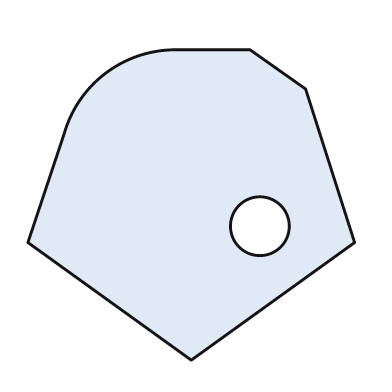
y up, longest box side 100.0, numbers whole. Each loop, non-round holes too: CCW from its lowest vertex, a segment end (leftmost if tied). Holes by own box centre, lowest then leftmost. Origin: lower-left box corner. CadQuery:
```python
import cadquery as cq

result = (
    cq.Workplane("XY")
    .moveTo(50.0, 0.0)
    .lineTo(100.0, 36.0)
    .lineTo(85.0, 83.0)
    .lineTo(68.0, 95.0)
    .lineTo(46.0, 95.0)
    .threePointArc((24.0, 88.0), (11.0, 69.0))
    .lineTo(0.0, 36.0)
    .close()
    .moveTo(71.0, 41.0)
    .circle(9.0)
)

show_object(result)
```